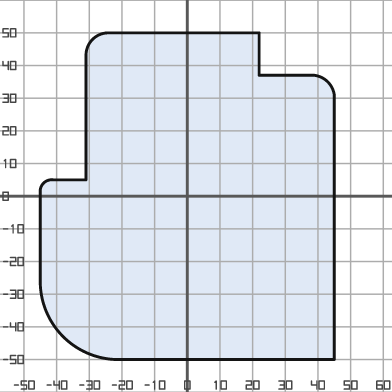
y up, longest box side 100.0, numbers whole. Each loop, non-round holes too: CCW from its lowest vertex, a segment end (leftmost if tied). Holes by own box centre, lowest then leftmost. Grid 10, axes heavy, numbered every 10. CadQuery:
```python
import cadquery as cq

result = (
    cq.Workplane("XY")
    .moveTo(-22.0, -50.0)
    .lineTo(45.0, -50.0)
    .lineTo(45.0, 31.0)
    .threePointArc((43.0, 35.0), (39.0, 37.0))
    .lineTo(22.0, 37.0)
    .lineTo(22.0, 50.0)
    .lineTo(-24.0, 50.0)
    .threePointArc((-29.0, 48.0), (-31.0, 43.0))
    .lineTo(-31.0, 5.0)
    .lineTo(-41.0, 5.0)
    .threePointArc((-44.0, 4.0), (-45.0, 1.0))
    .lineTo(-45.0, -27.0)
    .threePointArc((-38.0, -43.0), (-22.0, -50.0))
    .close()
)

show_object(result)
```